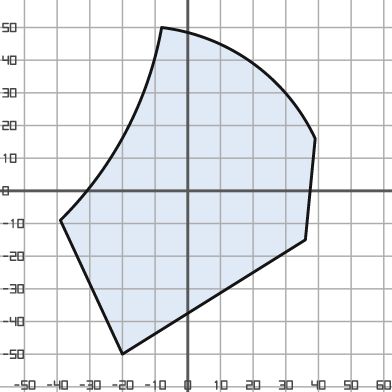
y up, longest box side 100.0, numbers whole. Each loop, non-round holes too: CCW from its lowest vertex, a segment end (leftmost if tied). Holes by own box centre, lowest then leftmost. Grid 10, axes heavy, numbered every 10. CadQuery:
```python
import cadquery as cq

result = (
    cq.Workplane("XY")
    .moveTo(-20.0, -50.0)
    .lineTo(36.0, -15.0)
    .lineTo(39.0, 16.0)
    .threePointArc((20.0, 39.0), (-8.0, 50.0))
    .threePointArc((-19.0, 18.0), (-39.0, -9.0))
    .close()
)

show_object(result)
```